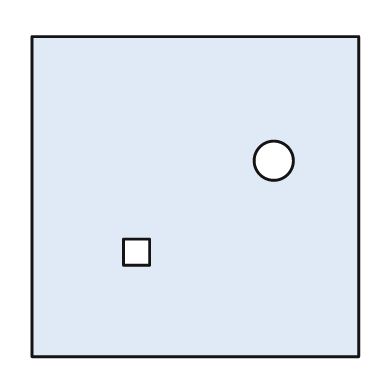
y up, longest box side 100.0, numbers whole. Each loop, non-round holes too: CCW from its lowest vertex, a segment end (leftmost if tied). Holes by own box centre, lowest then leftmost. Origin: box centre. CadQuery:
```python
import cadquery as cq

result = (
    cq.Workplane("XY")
    .moveTo(-50.0, -49.0)
    .lineTo(50.0, -49.0)
    .lineTo(50.0, 49.0)
    .lineTo(-50.0, 49.0)
    .close()
    .moveTo(-22.0, -21.0)
    .lineTo(-14.0, -21.0)
    .lineTo(-14.0, -13.0)
    .lineTo(-22.0, -13.0)
    .close()
    .moveTo(24.0, 11.0)
    .circle(6.0)
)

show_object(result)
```